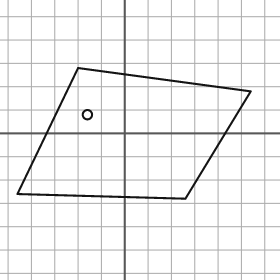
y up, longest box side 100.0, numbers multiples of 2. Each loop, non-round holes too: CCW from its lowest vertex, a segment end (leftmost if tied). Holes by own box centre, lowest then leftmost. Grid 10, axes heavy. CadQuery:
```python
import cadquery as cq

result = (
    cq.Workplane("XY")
    .moveTo(26.0, -28.0)
    .lineTo(54.0, 18.0)
    .lineTo(-20.0, 28.0)
    .lineTo(-46.0, -26.0)
    .close()
    .moveTo(-16.0, 8.0)
    .circle(2.0)
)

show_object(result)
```